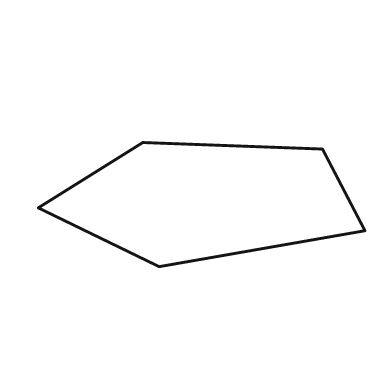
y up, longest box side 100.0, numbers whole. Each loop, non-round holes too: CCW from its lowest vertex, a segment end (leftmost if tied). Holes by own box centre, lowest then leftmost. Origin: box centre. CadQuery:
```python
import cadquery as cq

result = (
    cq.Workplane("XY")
    .moveTo(-13.0, -19.0)
    .lineTo(50.0, -8.0)
    .lineTo(37.0, 17.0)
    .lineTo(-18.0, 19.0)
    .lineTo(-50.0, -1.0)
    .close()
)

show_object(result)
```